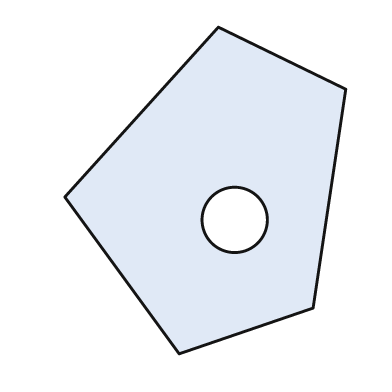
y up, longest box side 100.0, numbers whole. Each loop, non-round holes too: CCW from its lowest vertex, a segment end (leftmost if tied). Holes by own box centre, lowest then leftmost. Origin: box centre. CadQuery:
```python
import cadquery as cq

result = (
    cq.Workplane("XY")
    .moveTo(-8.0, -50.0)
    .lineTo(33.0, -36.0)
    .lineTo(43.0, 31.0)
    .lineTo(4.0, 50.0)
    .lineTo(-43.0, -2.0)
    .close()
    .moveTo(9.0, -9.0)
    .circle(10.0)
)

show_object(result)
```